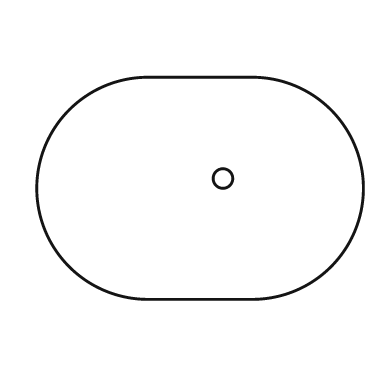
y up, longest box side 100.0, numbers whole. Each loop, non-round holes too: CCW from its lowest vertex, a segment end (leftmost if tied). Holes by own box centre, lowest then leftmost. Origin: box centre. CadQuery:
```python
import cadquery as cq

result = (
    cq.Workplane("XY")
    .moveTo(-16.0, -34.0)
    .lineTo(16.0, -34.0)
    .threePointArc((50.0, 0.0), (16.0, 34.0))
    .lineTo(-16.0, 34.0)
    .threePointArc((-50.0, 0.0), (-16.0, -34.0))
    .close()
    .moveTo(7.0, 3.0)
    .circle(3.0)
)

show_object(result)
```